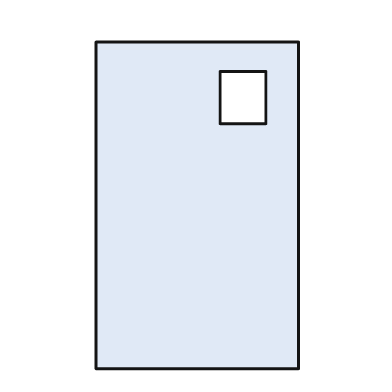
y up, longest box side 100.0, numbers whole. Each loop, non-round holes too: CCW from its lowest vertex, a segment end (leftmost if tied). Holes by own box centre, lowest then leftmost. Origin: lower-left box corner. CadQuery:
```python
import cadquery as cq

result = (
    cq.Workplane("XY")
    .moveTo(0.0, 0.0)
    .lineTo(62.0, 0.0)
    .lineTo(62.0, 100.0)
    .lineTo(0.0, 100.0)
    .close()
    .moveTo(38.0, 75.0)
    .lineTo(52.0, 75.0)
    .lineTo(52.0, 91.0)
    .lineTo(38.0, 91.0)
    .close()
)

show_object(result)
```